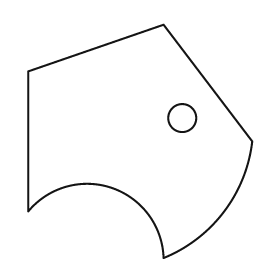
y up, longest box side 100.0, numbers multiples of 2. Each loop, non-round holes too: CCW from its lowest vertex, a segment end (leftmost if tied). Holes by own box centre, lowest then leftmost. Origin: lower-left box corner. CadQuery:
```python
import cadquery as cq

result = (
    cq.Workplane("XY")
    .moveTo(58.0, 0.0)
    .threePointArc((84.0, 20.0), (96.0, 50.0))
    .lineTo(58.0, 100.0)
    .lineTo(0.0, 80.0)
    .lineTo(0.0, 20.0)
    .threePointArc((36.0, 30.0), (58.0, 0.0))
    .close()
    .moveTo(66.0, 60.0)
    .circle(6.0)
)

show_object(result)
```